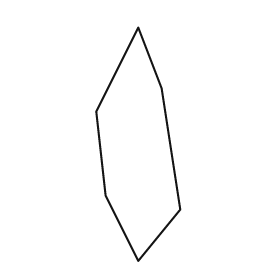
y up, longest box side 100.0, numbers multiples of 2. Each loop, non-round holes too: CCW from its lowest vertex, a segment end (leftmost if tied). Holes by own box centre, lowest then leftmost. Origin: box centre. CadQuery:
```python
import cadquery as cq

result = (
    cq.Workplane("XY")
    .moveTo(0.0, -50.0)
    .lineTo(18.0, -28.0)
    .lineTo(10.0, 24.0)
    .lineTo(0.0, 50.0)
    .lineTo(-18.0, 14.0)
    .lineTo(-14.0, -22.0)
    .close()
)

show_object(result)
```